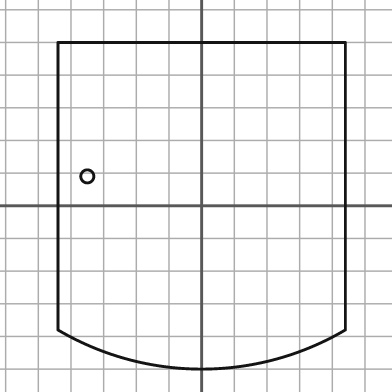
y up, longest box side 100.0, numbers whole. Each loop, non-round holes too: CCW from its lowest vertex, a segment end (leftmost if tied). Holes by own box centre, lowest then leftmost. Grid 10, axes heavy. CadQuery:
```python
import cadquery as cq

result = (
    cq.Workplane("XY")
    .moveTo(-44.0, -38.0)
    .threePointArc((0.0, -50.0), (44.0, -38.0))
    .lineTo(44.0, 50.0)
    .lineTo(-44.0, 50.0)
    .close()
    .moveTo(-35.0, 9.0)
    .circle(2.0)
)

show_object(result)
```